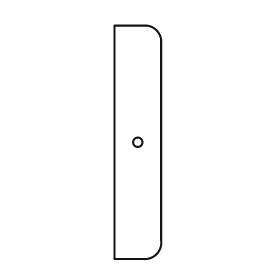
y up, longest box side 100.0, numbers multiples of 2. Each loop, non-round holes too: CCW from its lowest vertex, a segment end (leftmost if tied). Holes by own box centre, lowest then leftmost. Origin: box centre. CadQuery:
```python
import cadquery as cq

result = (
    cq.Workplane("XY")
    .moveTo(-10.0, -50.0)
    .lineTo(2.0, -50.0)
    .threePointArc((8.0, -48.0), (10.0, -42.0))
    .lineTo(10.0, 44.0)
    .threePointArc((8.0, 48.0), (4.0, 50.0))
    .lineTo(-10.0, 50.0)
    .close()
    .moveTo(0.0, 0.0)
    .circle(2.0)
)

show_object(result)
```